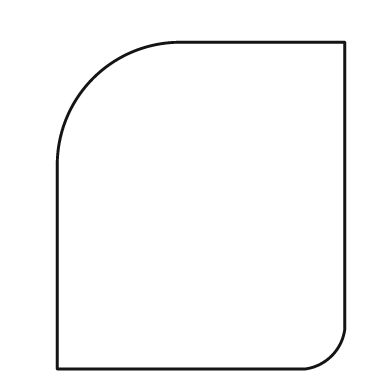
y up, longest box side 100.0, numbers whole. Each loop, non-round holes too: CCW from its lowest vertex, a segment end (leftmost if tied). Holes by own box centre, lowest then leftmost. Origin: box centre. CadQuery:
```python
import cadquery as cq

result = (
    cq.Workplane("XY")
    .moveTo(-44.0, -50.0)
    .lineTo(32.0, -50.0)
    .threePointArc((40.0, -46.0), (44.0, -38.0))
    .lineTo(44.0, 50.0)
    .lineTo(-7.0, 50.0)
    .threePointArc((-33.0, 39.0), (-44.0, 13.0))
    .close()
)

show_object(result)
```